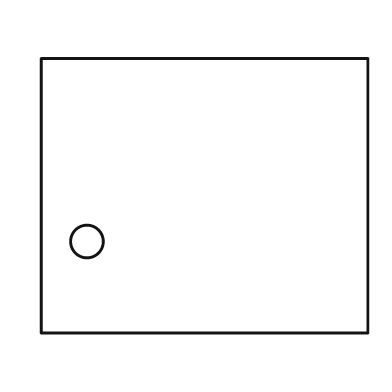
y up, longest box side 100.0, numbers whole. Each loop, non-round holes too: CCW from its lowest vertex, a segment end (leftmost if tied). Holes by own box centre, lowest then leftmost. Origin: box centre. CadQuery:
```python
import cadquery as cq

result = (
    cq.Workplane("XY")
    .moveTo(-50.0, -42.0)
    .lineTo(50.0, -42.0)
    .lineTo(50.0, 42.0)
    .lineTo(-50.0, 42.0)
    .close()
    .moveTo(-36.0, -14.0)
    .circle(5.0)
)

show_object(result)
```